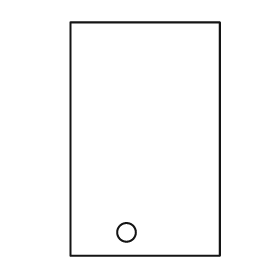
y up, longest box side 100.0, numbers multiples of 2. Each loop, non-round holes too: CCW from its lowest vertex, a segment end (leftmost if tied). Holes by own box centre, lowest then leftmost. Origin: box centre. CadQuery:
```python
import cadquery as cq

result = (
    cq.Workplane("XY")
    .moveTo(-32.0, -50.0)
    .lineTo(32.0, -50.0)
    .lineTo(32.0, 50.0)
    .lineTo(-32.0, 50.0)
    .close()
    .moveTo(-8.0, -40.0)
    .circle(4.0)
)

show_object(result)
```